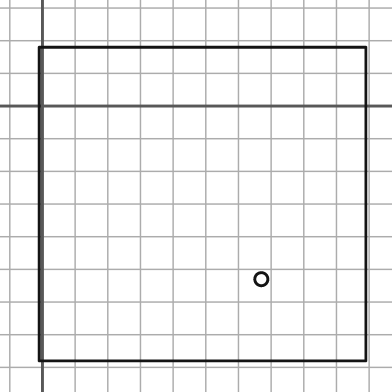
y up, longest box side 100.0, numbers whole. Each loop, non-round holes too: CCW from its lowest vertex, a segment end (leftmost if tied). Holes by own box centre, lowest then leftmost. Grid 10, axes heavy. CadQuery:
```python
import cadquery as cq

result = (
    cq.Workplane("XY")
    .moveTo(-1.0, -78.0)
    .lineTo(99.0, -78.0)
    .lineTo(99.0, 18.0)
    .lineTo(-1.0, 18.0)
    .close()
    .moveTo(67.0, -53.0)
    .circle(2.0)
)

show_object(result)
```